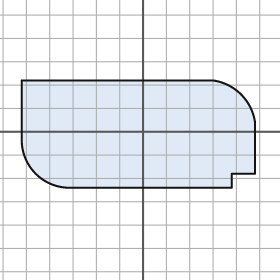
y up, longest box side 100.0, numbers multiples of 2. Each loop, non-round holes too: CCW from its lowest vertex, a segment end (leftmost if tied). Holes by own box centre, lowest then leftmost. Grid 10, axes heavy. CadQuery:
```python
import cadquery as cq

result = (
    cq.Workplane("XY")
    .moveTo(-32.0, -24.0)
    .lineTo(38.0, -24.0)
    .lineTo(38.0, -18.0)
    .lineTo(48.0, -18.0)
    .lineTo(48.0, 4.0)
    .threePointArc((42.0, 16.0), (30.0, 22.0))
    .lineTo(-52.0, 22.0)
    .lineTo(-52.0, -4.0)
    .threePointArc((-46.0, -18.0), (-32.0, -24.0))
    .close()
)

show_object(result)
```